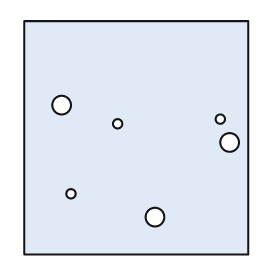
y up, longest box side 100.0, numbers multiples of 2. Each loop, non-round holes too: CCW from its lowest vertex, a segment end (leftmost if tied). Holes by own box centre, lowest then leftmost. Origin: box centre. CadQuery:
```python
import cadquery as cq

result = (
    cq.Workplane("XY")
    .moveTo(-48.0, -50.0)
    .lineTo(48.0, -50.0)
    .lineTo(48.0, 50.0)
    .lineTo(-48.0, 50.0)
    .close()
    .moveTo(8.0, -34.0)
    .circle(4.0)
    .moveTo(-28.0, -24.0)
    .circle(2.0)
    .moveTo(40.0, -2.0)
    .circle(4.0)
    .moveTo(-8.0, 6.0)
    .circle(2.0)
    .moveTo(36.0, 8.0)
    .circle(2.0)
    .moveTo(-32.0, 14.0)
    .circle(4.0)
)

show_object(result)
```